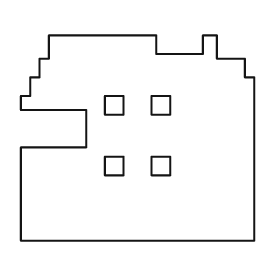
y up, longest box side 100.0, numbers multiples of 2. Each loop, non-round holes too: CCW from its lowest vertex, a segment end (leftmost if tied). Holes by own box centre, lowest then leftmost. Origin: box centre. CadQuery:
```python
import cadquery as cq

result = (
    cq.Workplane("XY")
    .moveTo(-50.0, -44.0)
    .lineTo(50.0, -44.0)
    .lineTo(50.0, 26.0)
    .lineTo(46.0, 26.0)
    .lineTo(46.0, 34.0)
    .lineTo(34.0, 34.0)
    .lineTo(34.0, 44.0)
    .lineTo(28.0, 44.0)
    .lineTo(28.0, 36.0)
    .lineTo(8.0, 36.0)
    .lineTo(8.0, 44.0)
    .lineTo(-38.0, 44.0)
    .lineTo(-38.0, 34.0)
    .lineTo(-42.0, 34.0)
    .lineTo(-42.0, 26.0)
    .lineTo(-46.0, 26.0)
    .lineTo(-46.0, 18.0)
    .lineTo(-50.0, 18.0)
    .lineTo(-50.0, 12.0)
    .lineTo(-22.0, 12.0)
    .lineTo(-22.0, -4.0)
    .lineTo(-50.0, -4.0)
    .close()
    .moveTo(-14.0, -16.0)
    .lineTo(-6.0, -16.0)
    .lineTo(-6.0, -8.0)
    .lineTo(-14.0, -8.0)
    .close()
    .moveTo(6.0, -16.0)
    .lineTo(14.0, -16.0)
    .lineTo(14.0, -8.0)
    .lineTo(6.0, -8.0)
    .close()
    .moveTo(-14.0, 10.0)
    .lineTo(-6.0, 10.0)
    .lineTo(-6.0, 18.0)
    .lineTo(-14.0, 18.0)
    .close()
    .moveTo(6.0, 10.0)
    .lineTo(14.0, 10.0)
    .lineTo(14.0, 18.0)
    .lineTo(6.0, 18.0)
    .close()
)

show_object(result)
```